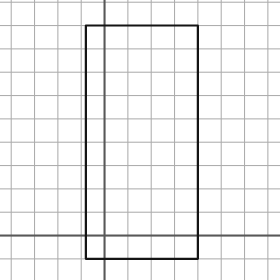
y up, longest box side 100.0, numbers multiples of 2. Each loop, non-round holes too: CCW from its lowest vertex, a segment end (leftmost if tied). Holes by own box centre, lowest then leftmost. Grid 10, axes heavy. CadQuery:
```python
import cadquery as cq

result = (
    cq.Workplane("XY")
    .moveTo(-8.0, -10.0)
    .lineTo(40.0, -10.0)
    .lineTo(40.0, 90.0)
    .lineTo(-8.0, 90.0)
    .close()
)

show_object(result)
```